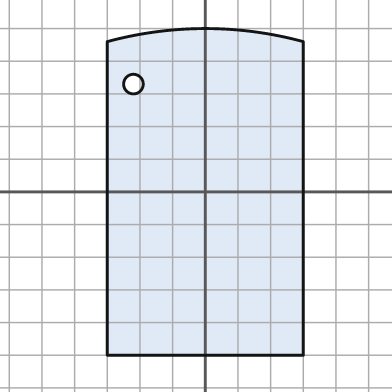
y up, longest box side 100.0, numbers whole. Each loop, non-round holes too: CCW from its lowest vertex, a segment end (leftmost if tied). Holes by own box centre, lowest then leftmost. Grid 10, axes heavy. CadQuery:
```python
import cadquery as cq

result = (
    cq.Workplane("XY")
    .moveTo(-30.0, -50.0)
    .lineTo(30.0, -50.0)
    .lineTo(30.0, 46.0)
    .threePointArc((0.0, 50.0), (-30.0, 46.0))
    .close()
    .moveTo(-22.0, 33.0)
    .circle(3.0)
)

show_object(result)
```